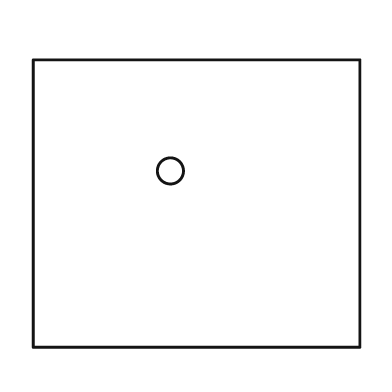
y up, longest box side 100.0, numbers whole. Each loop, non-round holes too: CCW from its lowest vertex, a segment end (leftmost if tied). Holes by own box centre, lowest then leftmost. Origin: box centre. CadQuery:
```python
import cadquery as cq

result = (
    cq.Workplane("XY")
    .moveTo(-50.0, -44.0)
    .lineTo(50.0, -44.0)
    .lineTo(50.0, 44.0)
    .lineTo(-50.0, 44.0)
    .close()
    .moveTo(-8.0, 10.0)
    .circle(4.0)
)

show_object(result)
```